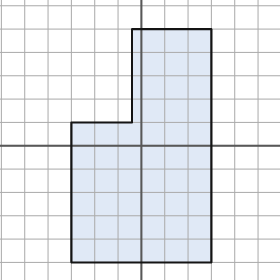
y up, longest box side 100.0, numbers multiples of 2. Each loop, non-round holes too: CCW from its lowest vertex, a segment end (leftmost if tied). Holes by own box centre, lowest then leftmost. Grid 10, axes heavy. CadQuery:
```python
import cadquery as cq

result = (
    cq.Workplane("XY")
    .moveTo(-30.0, -50.0)
    .lineTo(30.0, -50.0)
    .lineTo(30.0, 50.0)
    .lineTo(-4.0, 50.0)
    .lineTo(-4.0, 10.0)
    .lineTo(-30.0, 10.0)
    .close()
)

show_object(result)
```